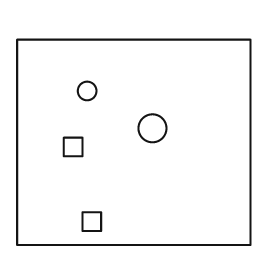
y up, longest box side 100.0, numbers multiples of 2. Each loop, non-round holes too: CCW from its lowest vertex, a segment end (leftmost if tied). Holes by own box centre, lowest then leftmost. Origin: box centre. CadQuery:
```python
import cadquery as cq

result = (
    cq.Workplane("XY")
    .moveTo(-50.0, -44.0)
    .lineTo(50.0, -44.0)
    .lineTo(50.0, 44.0)
    .lineTo(-50.0, 44.0)
    .close()
    .moveTo(-22.0, -38.0)
    .lineTo(-14.0, -38.0)
    .lineTo(-14.0, -30.0)
    .lineTo(-22.0, -30.0)
    .close()
    .moveTo(-30.0, -6.0)
    .lineTo(-22.0, -6.0)
    .lineTo(-22.0, 2.0)
    .lineTo(-30.0, 2.0)
    .close()
    .moveTo(8.0, 6.0)
    .circle(6.0)
    .moveTo(-20.0, 22.0)
    .circle(4.0)
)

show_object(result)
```